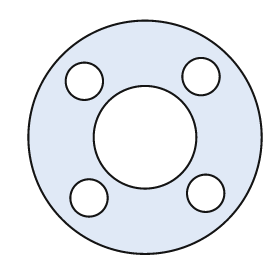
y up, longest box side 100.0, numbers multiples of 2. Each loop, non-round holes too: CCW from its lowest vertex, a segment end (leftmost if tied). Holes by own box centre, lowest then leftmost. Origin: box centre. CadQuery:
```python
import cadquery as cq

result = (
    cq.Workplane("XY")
    .moveTo(0.0, 0.0)
    .circle(50.0)
    .moveTo(-24.0, -26.0)
    .circle(8.0)
    .moveTo(26.0, -24.0)
    .circle(8.0)
    .moveTo(0.0, 0.0)
    .circle(22.0)
    .moveTo(-26.0, 24.0)
    .circle(8.0)
    .moveTo(24.0, 26.0)
    .circle(8.0)
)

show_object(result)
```